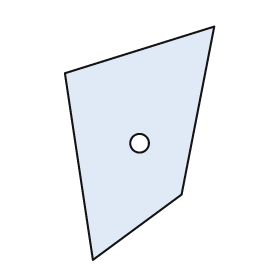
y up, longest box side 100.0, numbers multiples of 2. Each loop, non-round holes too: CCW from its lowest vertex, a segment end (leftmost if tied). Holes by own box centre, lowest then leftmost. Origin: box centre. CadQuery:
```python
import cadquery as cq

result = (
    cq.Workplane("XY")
    .moveTo(-20.0, -50.0)
    .lineTo(18.0, -22.0)
    .lineTo(32.0, 50.0)
    .lineTo(-32.0, 30.0)
    .close()
    .moveTo(0.0, 0.0)
    .circle(4.0)
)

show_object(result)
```